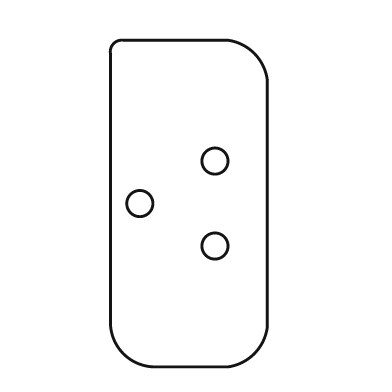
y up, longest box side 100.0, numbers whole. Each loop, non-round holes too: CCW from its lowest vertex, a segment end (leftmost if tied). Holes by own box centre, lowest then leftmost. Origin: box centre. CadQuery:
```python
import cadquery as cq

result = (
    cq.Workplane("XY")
    .moveTo(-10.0, -50.0)
    .lineTo(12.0, -50.0)
    .threePointArc((20.0, -46.0), (24.0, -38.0))
    .lineTo(24.0, 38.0)
    .threePointArc((20.0, 46.0), (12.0, 50.0))
    .lineTo(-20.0, 50.0)
    .threePointArc((-23.0, 49.0), (-24.0, 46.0))
    .lineTo(-24.0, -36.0)
    .threePointArc((-20.0, -46.0), (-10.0, -50.0))
    .close()
    .moveTo(8.0, -13.0)
    .circle(4.0)
    .moveTo(-15.0, 0.0)
    .circle(4.0)
    .moveTo(8.0, 13.0)
    .circle(4.0)
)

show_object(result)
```